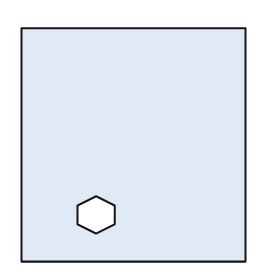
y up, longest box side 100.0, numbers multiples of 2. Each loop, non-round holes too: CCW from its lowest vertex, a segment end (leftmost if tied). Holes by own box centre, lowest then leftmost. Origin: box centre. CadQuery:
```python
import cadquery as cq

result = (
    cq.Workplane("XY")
    .moveTo(-48.0, -50.0)
    .lineTo(48.0, -50.0)
    .lineTo(48.0, 50.0)
    .lineTo(-48.0, 50.0)
    .close()
    .moveTo(-16.0, -38.0)
    .lineTo(-8.0, -34.0)
    .lineTo(-8.0, -26.0)
    .lineTo(-16.0, -22.0)
    .lineTo(-24.0, -26.0)
    .lineTo(-24.0, -34.0)
    .close()
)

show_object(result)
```